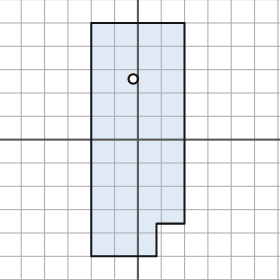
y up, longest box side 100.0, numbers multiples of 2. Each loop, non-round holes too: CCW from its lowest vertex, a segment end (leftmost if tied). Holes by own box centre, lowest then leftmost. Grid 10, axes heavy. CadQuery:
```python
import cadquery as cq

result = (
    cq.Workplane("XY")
    .moveTo(-20.0, -50.0)
    .lineTo(8.0, -50.0)
    .lineTo(8.0, -36.0)
    .lineTo(20.0, -36.0)
    .lineTo(20.0, 50.0)
    .lineTo(-20.0, 50.0)
    .close()
    .moveTo(-2.0, 26.0)
    .circle(2.0)
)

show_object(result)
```